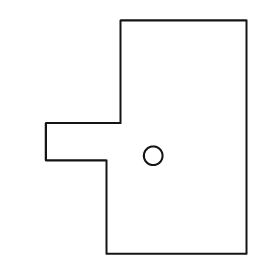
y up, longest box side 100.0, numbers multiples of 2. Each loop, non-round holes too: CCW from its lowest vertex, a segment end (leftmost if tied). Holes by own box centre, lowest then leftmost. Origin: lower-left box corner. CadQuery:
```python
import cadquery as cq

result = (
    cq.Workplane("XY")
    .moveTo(26.0, 0.0)
    .lineTo(86.0, 0.0)
    .lineTo(86.0, 100.0)
    .lineTo(32.0, 100.0)
    .lineTo(32.0, 56.0)
    .lineTo(0.0, 56.0)
    .lineTo(0.0, 40.0)
    .lineTo(26.0, 40.0)
    .close()
    .moveTo(46.0, 42.0)
    .circle(4.0)
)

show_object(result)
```